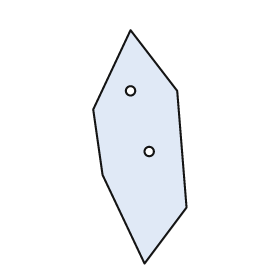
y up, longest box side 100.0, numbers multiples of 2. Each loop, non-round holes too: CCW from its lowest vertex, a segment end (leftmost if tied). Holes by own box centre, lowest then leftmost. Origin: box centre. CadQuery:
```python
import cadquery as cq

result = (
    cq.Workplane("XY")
    .moveTo(2.0, -50.0)
    .lineTo(20.0, -26.0)
    .lineTo(16.0, 24.0)
    .lineTo(-4.0, 50.0)
    .lineTo(-20.0, 16.0)
    .lineTo(-16.0, -12.0)
    .close()
    .moveTo(4.0, -2.0)
    .circle(2.0)
    .moveTo(-4.0, 24.0)
    .circle(2.0)
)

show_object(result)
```